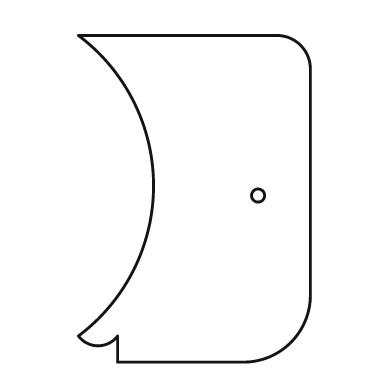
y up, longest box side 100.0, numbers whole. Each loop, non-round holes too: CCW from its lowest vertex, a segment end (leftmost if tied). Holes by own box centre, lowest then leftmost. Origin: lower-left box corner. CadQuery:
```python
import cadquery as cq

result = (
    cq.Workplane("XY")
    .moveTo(12.0, 0.0)
    .lineTo(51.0, 0.0)
    .threePointArc((65.0, 6.0), (71.0, 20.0))
    .lineTo(71.0, 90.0)
    .threePointArc((68.0, 97.0), (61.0, 100.0))
    .lineTo(0.0, 100.0)
    .threePointArc((23.0, 54.0), (0.0, 8.0))
    .threePointArc((6.0, 5.0), (12.0, 8.0))
    .close()
    .moveTo(55.0, 51.0)
    .circle(2.0)
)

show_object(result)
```